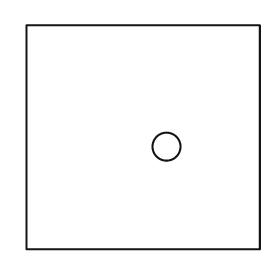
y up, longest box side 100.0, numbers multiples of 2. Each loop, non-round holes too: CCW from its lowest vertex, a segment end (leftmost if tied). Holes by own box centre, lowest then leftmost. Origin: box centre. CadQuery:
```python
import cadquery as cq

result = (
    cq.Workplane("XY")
    .moveTo(-50.0, -48.0)
    .lineTo(50.0, -48.0)
    .lineTo(50.0, 48.0)
    .lineTo(-50.0, 48.0)
    .close()
    .moveTo(10.0, -4.0)
    .circle(6.0)
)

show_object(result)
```